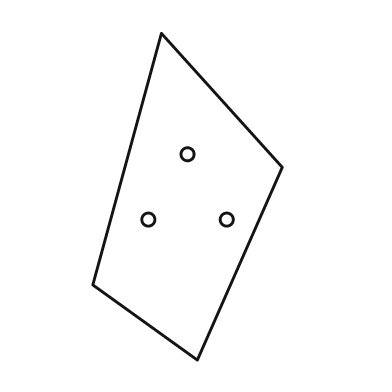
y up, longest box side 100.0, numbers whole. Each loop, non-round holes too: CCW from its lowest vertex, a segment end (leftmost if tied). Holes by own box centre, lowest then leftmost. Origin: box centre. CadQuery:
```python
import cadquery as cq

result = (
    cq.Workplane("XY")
    .moveTo(3.0, -50.0)
    .lineTo(29.0, 9.0)
    .lineTo(-8.0, 50.0)
    .lineTo(-29.0, -27.0)
    .close()
    .moveTo(-12.0, -7.0)
    .circle(2.0)
    .moveTo(12.0, -7.0)
    .circle(2.0)
    .moveTo(0.0, 13.0)
    .circle(2.0)
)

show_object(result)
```